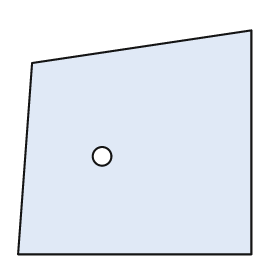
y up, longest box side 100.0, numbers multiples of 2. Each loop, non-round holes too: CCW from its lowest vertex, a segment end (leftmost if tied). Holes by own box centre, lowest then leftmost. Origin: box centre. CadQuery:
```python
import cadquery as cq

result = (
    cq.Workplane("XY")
    .moveTo(-50.0, -48.0)
    .lineTo(50.0, -48.0)
    .lineTo(50.0, 48.0)
    .lineTo(-44.0, 34.0)
    .close()
    .moveTo(-14.0, -6.0)
    .circle(4.0)
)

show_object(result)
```